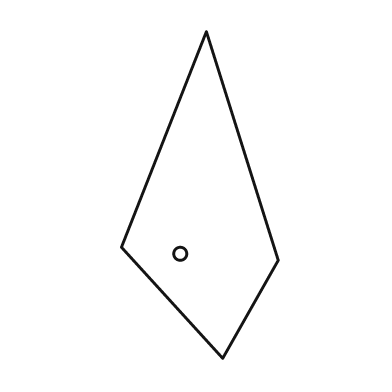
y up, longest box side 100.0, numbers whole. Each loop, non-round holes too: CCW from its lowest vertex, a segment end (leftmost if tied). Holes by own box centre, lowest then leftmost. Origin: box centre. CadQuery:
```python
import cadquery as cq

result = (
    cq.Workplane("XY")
    .moveTo(7.0, -50.0)
    .lineTo(24.0, -20.0)
    .lineTo(2.0, 50.0)
    .lineTo(-24.0, -16.0)
    .close()
    .moveTo(-6.0, -18.0)
    .circle(2.0)
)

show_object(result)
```